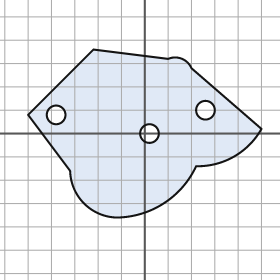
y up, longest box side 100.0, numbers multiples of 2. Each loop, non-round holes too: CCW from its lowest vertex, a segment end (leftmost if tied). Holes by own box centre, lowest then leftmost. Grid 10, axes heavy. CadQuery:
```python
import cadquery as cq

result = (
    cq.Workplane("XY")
    .moveTo(-12.0, -36.0)
    .threePointArc((8.0, -30.0), (22.0, -14.0))
    .threePointArc((38.0, -10.0), (50.0, 2.0))
    .lineTo(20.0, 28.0)
    .threePointArc((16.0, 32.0), (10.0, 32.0))
    .lineTo(-22.0, 36.0)
    .lineTo(-50.0, 8.0)
    .lineTo(-32.0, -16.0)
    .threePointArc((-26.0, -30.0), (-12.0, -36.0))
    .close()
    .moveTo(2.0, 0.0)
    .circle(4.0)
    .moveTo(-38.0, 8.0)
    .circle(4.0)
    .moveTo(26.0, 10.0)
    .circle(4.0)
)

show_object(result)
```